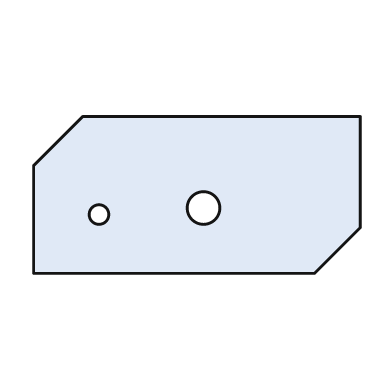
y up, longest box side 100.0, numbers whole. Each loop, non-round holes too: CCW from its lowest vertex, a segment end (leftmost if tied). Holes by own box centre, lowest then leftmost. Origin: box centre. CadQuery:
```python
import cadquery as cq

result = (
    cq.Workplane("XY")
    .moveTo(-50.0, -24.0)
    .lineTo(36.0, -24.0)
    .lineTo(50.0, -10.0)
    .lineTo(50.0, 24.0)
    .lineTo(-35.0, 24.0)
    .lineTo(-50.0, 9.0)
    .close()
    .moveTo(-30.0, -6.0)
    .circle(3.0)
    .moveTo(2.0, -4.0)
    .circle(5.0)
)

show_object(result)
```